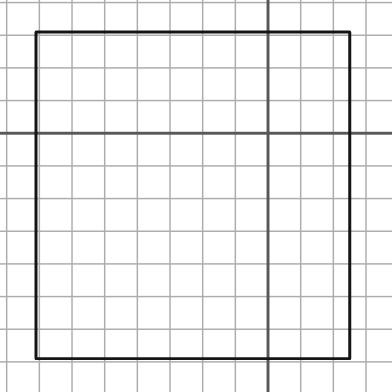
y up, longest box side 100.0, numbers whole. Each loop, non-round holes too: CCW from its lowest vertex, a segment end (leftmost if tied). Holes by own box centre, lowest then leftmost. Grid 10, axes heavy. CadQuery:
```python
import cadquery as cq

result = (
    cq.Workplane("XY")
    .moveTo(-71.0, -69.0)
    .lineTo(25.0, -69.0)
    .lineTo(25.0, 31.0)
    .lineTo(-71.0, 31.0)
    .close()
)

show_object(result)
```